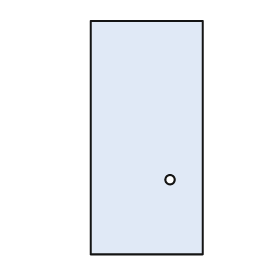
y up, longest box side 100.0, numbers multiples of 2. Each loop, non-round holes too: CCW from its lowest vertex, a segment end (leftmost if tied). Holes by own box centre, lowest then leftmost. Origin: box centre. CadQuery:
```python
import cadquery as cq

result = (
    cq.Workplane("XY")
    .moveTo(-24.0, -50.0)
    .lineTo(24.0, -50.0)
    .lineTo(24.0, 50.0)
    .lineTo(-24.0, 50.0)
    .close()
    .moveTo(10.0, -18.0)
    .circle(2.0)
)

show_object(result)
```